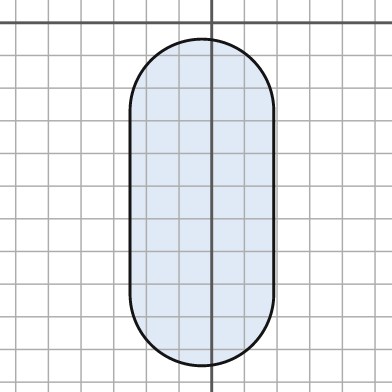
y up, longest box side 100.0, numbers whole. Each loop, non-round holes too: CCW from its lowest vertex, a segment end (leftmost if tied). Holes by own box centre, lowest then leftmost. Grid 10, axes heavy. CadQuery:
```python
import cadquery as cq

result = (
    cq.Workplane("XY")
    .moveTo(-25.0, -83.0)
    .threePointArc((-3.0, -105.0), (19.0, -83.0))
    .lineTo(19.0, -27.0)
    .threePointArc((-3.0, -5.0), (-25.0, -27.0))
    .close()
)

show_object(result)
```